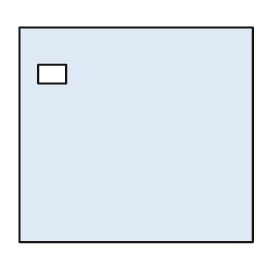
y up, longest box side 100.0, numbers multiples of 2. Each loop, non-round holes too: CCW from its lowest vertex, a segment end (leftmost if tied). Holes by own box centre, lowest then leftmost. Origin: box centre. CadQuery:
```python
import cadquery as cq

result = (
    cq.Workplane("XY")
    .moveTo(-50.0, -46.0)
    .lineTo(50.0, -46.0)
    .lineTo(50.0, 46.0)
    .lineTo(-50.0, 46.0)
    .close()
    .moveTo(-42.0, 22.0)
    .lineTo(-30.0, 22.0)
    .lineTo(-30.0, 30.0)
    .lineTo(-42.0, 30.0)
    .close()
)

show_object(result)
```